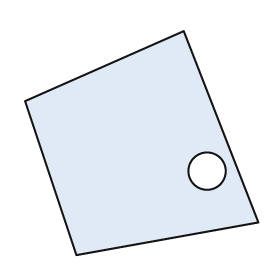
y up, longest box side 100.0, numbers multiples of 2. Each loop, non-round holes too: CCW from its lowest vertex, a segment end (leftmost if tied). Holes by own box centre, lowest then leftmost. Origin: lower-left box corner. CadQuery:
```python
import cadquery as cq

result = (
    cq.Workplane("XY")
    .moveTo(22.0, 0.0)
    .lineTo(100.0, 14.0)
    .lineTo(68.0, 96.0)
    .lineTo(0.0, 66.0)
    .close()
    .moveTo(78.0, 36.0)
    .circle(8.0)
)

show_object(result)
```